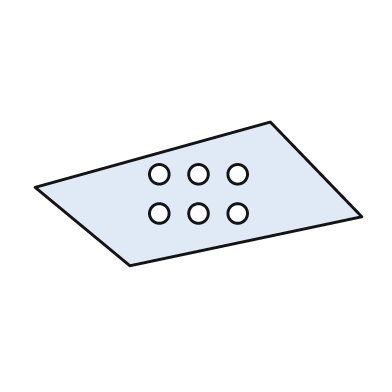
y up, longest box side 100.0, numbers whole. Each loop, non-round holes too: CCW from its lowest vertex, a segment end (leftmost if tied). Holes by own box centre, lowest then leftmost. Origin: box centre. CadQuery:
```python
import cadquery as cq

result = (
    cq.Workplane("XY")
    .moveTo(-21.0, -22.0)
    .lineTo(50.0, -7.0)
    .lineTo(22.0, 22.0)
    .lineTo(-50.0, 2.0)
    .close()
    .moveTo(-12.0, -6.0)
    .circle(3.0)
    .moveTo(0.0, -6.0)
    .circle(3.0)
    .moveTo(12.0, -6.0)
    .circle(3.0)
    .moveTo(-12.0, 6.0)
    .circle(3.0)
    .moveTo(0.0, 6.0)
    .circle(3.0)
    .moveTo(12.0, 6.0)
    .circle(3.0)
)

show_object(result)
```